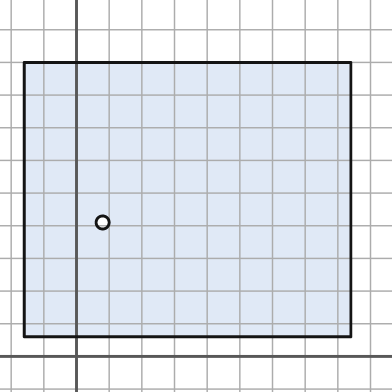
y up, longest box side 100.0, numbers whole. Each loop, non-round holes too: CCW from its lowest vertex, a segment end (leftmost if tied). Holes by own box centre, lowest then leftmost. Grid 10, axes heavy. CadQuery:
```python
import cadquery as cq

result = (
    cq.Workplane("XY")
    .moveTo(-16.0, 6.0)
    .lineTo(84.0, 6.0)
    .lineTo(84.0, 90.0)
    .lineTo(-16.0, 90.0)
    .close()
    .moveTo(8.0, 41.0)
    .circle(2.0)
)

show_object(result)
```